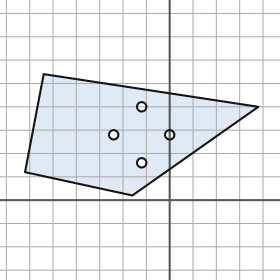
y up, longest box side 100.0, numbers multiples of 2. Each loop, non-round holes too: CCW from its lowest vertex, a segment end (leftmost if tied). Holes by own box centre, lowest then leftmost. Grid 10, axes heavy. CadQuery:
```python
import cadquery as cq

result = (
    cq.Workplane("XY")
    .moveTo(-16.0, 2.0)
    .lineTo(38.0, 40.0)
    .lineTo(-54.0, 54.0)
    .lineTo(-62.0, 12.0)
    .close()
    .moveTo(-12.0, 16.0)
    .circle(2.0)
    .moveTo(-24.0, 28.0)
    .circle(2.0)
    .moveTo(0.0, 28.0)
    .circle(2.0)
    .moveTo(-12.0, 40.0)
    .circle(2.0)
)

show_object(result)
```